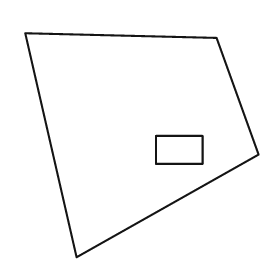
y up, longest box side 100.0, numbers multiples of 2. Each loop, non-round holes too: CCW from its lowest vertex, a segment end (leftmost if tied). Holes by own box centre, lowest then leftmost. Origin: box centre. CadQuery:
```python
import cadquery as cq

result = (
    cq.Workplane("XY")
    .moveTo(-28.0, -48.0)
    .lineTo(50.0, -4.0)
    .lineTo(32.0, 46.0)
    .lineTo(-50.0, 48.0)
    .close()
    .moveTo(6.0, -8.0)
    .lineTo(26.0, -8.0)
    .lineTo(26.0, 4.0)
    .lineTo(6.0, 4.0)
    .close()
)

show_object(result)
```